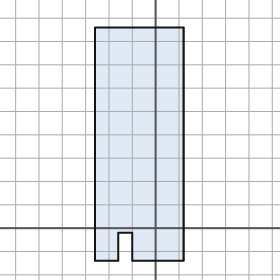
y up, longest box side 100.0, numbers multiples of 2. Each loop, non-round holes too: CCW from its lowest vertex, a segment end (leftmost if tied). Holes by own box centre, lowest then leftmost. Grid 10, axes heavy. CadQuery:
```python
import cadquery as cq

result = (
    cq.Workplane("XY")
    .moveTo(-26.0, -14.0)
    .lineTo(-16.0, -14.0)
    .lineTo(-16.0, -2.0)
    .lineTo(-10.0, -2.0)
    .lineTo(-10.0, -14.0)
    .lineTo(12.0, -14.0)
    .lineTo(12.0, 86.0)
    .lineTo(-26.0, 86.0)
    .close()
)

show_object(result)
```